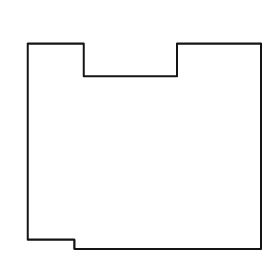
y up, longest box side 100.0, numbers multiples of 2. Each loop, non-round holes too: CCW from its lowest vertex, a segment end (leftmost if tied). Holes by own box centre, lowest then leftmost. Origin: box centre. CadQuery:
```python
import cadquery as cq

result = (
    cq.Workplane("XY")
    .moveTo(-30.0, -44.0)
    .lineTo(50.0, -44.0)
    .lineTo(50.0, 44.0)
    .lineTo(14.0, 44.0)
    .lineTo(14.0, 30.0)
    .lineTo(-26.0, 30.0)
    .lineTo(-26.0, 44.0)
    .lineTo(-50.0, 44.0)
    .lineTo(-50.0, -40.0)
    .lineTo(-30.0, -40.0)
    .close()
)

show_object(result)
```